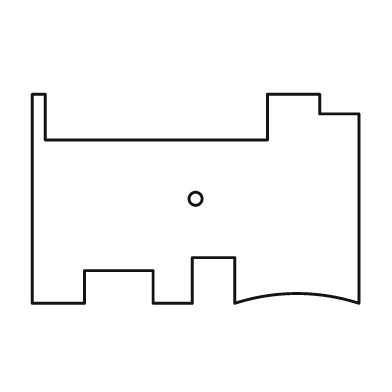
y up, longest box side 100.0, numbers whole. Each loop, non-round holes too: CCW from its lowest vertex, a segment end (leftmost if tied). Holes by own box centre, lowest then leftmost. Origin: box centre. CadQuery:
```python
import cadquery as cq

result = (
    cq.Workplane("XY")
    .moveTo(-50.0, -32.0)
    .lineTo(-34.0, -32.0)
    .lineTo(-34.0, -22.0)
    .lineTo(-13.0, -22.0)
    .lineTo(-13.0, -32.0)
    .lineTo(-1.0, -32.0)
    .lineTo(-1.0, -18.0)
    .lineTo(12.0, -18.0)
    .lineTo(12.0, -32.0)
    .threePointArc((31.0, -29.0), (50.0, -32.0))
    .lineTo(50.0, 26.0)
    .lineTo(38.0, 26.0)
    .lineTo(38.0, 32.0)
    .lineTo(22.0, 32.0)
    .lineTo(22.0, 18.0)
    .lineTo(-46.0, 18.0)
    .lineTo(-46.0, 32.0)
    .lineTo(-50.0, 32.0)
    .close()
    .moveTo(0.0, 0.0)
    .circle(2.0)
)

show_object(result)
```